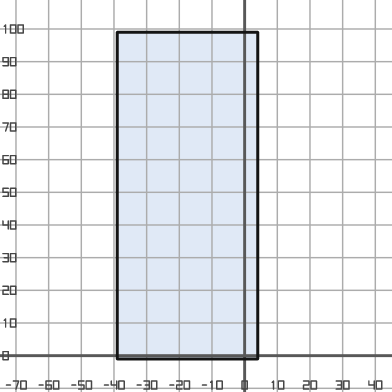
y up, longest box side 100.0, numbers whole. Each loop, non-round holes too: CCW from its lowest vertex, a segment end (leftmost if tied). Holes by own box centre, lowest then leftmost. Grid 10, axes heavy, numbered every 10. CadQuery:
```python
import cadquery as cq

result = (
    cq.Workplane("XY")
    .moveTo(-39.0, -1.0)
    .lineTo(4.0, -1.0)
    .lineTo(4.0, 99.0)
    .lineTo(-39.0, 99.0)
    .close()
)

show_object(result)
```